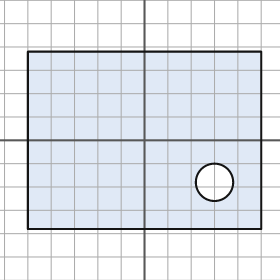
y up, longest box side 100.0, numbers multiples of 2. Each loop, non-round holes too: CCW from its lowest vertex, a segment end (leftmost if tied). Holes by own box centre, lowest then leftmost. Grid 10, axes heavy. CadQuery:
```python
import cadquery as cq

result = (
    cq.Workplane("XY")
    .moveTo(-50.0, -38.0)
    .lineTo(50.0, -38.0)
    .lineTo(50.0, 38.0)
    .lineTo(-50.0, 38.0)
    .close()
    .moveTo(30.0, -18.0)
    .circle(8.0)
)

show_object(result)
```